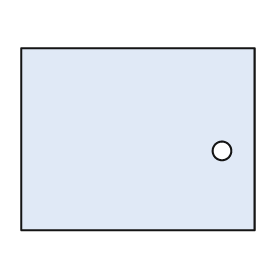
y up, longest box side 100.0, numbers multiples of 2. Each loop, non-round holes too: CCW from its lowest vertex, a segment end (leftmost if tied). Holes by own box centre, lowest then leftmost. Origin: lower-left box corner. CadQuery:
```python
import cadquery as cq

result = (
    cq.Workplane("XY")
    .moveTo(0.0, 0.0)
    .lineTo(100.0, 0.0)
    .lineTo(100.0, 78.0)
    .lineTo(0.0, 78.0)
    .close()
    .moveTo(86.0, 34.0)
    .circle(4.0)
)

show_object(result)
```